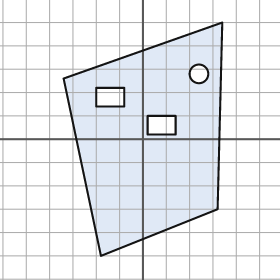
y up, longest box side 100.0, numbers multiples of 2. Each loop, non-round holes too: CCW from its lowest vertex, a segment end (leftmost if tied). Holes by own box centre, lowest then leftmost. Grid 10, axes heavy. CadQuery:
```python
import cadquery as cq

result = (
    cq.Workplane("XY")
    .moveTo(-18.0, -50.0)
    .lineTo(32.0, -30.0)
    .lineTo(34.0, 50.0)
    .lineTo(-34.0, 26.0)
    .close()
    .moveTo(2.0, 2.0)
    .lineTo(14.0, 2.0)
    .lineTo(14.0, 10.0)
    .lineTo(2.0, 10.0)
    .close()
    .moveTo(-20.0, 14.0)
    .lineTo(-8.0, 14.0)
    .lineTo(-8.0, 22.0)
    .lineTo(-20.0, 22.0)
    .close()
    .moveTo(24.0, 28.0)
    .circle(4.0)
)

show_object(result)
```